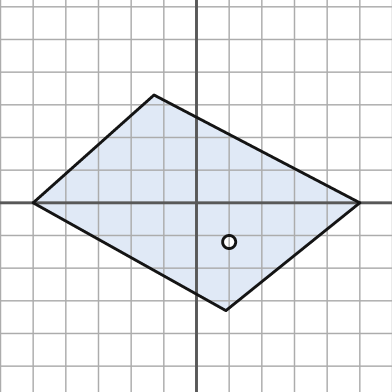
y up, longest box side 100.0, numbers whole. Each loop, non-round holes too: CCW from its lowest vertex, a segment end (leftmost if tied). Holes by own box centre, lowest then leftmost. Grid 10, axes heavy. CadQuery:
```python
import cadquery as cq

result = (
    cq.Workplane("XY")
    .moveTo(9.0, -33.0)
    .lineTo(50.0, 0.0)
    .lineTo(-13.0, 33.0)
    .lineTo(-50.0, 0.0)
    .close()
    .moveTo(10.0, -12.0)
    .circle(2.0)
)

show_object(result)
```